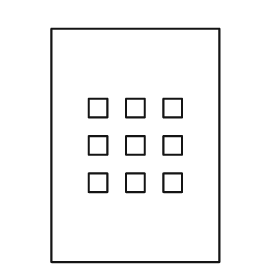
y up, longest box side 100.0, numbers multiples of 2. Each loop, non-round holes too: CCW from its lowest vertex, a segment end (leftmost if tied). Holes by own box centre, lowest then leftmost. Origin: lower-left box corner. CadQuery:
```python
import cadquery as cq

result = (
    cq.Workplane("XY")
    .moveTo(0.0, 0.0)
    .lineTo(72.0, 0.0)
    .lineTo(72.0, 100.0)
    .lineTo(0.0, 100.0)
    .close()
    .moveTo(16.0, 30.0)
    .lineTo(24.0, 30.0)
    .lineTo(24.0, 38.0)
    .lineTo(16.0, 38.0)
    .close()
    .moveTo(32.0, 30.0)
    .lineTo(40.0, 30.0)
    .lineTo(40.0, 38.0)
    .lineTo(32.0, 38.0)
    .close()
    .moveTo(48.0, 30.0)
    .lineTo(56.0, 30.0)
    .lineTo(56.0, 38.0)
    .lineTo(48.0, 38.0)
    .close()
    .moveTo(16.0, 46.0)
    .lineTo(24.0, 46.0)
    .lineTo(24.0, 54.0)
    .lineTo(16.0, 54.0)
    .close()
    .moveTo(32.0, 46.0)
    .lineTo(40.0, 46.0)
    .lineTo(40.0, 54.0)
    .lineTo(32.0, 54.0)
    .close()
    .moveTo(48.0, 46.0)
    .lineTo(56.0, 46.0)
    .lineTo(56.0, 54.0)
    .lineTo(48.0, 54.0)
    .close()
    .moveTo(16.0, 62.0)
    .lineTo(24.0, 62.0)
    .lineTo(24.0, 70.0)
    .lineTo(16.0, 70.0)
    .close()
    .moveTo(32.0, 62.0)
    .lineTo(40.0, 62.0)
    .lineTo(40.0, 70.0)
    .lineTo(32.0, 70.0)
    .close()
    .moveTo(48.0, 62.0)
    .lineTo(56.0, 62.0)
    .lineTo(56.0, 70.0)
    .lineTo(48.0, 70.0)
    .close()
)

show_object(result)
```